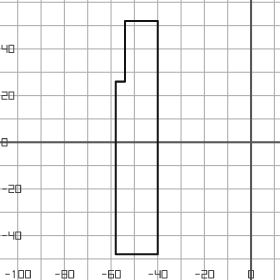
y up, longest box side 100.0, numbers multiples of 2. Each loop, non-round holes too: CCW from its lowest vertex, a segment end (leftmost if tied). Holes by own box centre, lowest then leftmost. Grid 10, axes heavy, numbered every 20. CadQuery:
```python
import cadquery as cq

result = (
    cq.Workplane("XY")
    .moveTo(-58.0, -48.0)
    .lineTo(-40.0, -48.0)
    .lineTo(-40.0, 52.0)
    .lineTo(-54.0, 52.0)
    .lineTo(-54.0, 26.0)
    .lineTo(-58.0, 26.0)
    .close()
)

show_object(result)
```